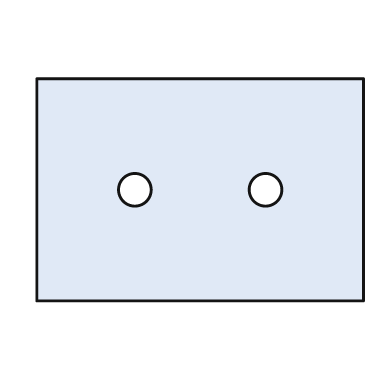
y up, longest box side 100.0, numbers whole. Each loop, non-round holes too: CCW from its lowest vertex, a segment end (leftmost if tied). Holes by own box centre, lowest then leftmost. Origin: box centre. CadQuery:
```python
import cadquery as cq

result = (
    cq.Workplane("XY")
    .moveTo(-50.0, -34.0)
    .lineTo(50.0, -34.0)
    .lineTo(50.0, 34.0)
    .lineTo(-50.0, 34.0)
    .close()
    .moveTo(-20.0, 0.0)
    .circle(5.0)
    .moveTo(20.0, 0.0)
    .circle(5.0)
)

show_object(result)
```